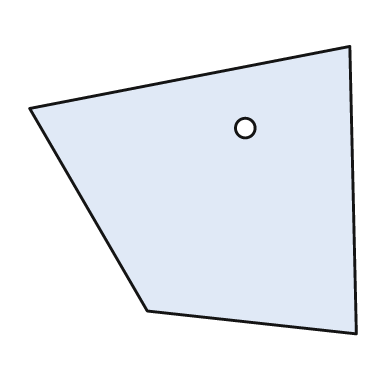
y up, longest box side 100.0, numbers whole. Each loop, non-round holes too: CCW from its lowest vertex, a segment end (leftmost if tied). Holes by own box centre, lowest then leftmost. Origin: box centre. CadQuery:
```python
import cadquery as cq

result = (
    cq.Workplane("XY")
    .moveTo(50.0, -44.0)
    .lineTo(48.0, 44.0)
    .lineTo(-50.0, 25.0)
    .lineTo(-14.0, -37.0)
    .close()
    .moveTo(16.0, 19.0)
    .circle(3.0)
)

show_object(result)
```